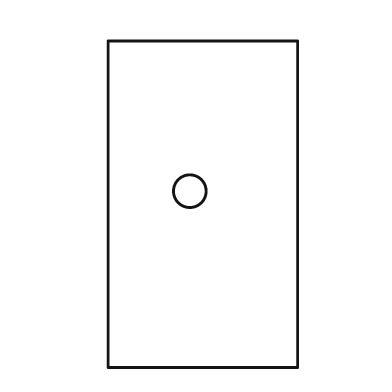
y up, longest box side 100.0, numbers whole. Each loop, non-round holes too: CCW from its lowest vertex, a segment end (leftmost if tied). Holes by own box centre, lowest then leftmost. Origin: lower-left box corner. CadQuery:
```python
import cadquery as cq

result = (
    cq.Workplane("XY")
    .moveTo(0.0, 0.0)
    .lineTo(58.0, 0.0)
    .lineTo(58.0, 100.0)
    .lineTo(0.0, 100.0)
    .close()
    .moveTo(25.0, 54.0)
    .circle(5.0)
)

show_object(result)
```